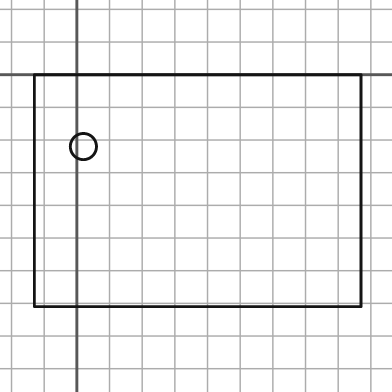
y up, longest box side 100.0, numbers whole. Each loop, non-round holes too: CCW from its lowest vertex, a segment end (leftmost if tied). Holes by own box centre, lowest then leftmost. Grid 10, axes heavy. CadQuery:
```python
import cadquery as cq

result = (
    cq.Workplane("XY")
    .moveTo(-13.0, -71.0)
    .lineTo(87.0, -71.0)
    .lineTo(87.0, 0.0)
    .lineTo(-13.0, 0.0)
    .close()
    .moveTo(2.0, -22.0)
    .circle(4.0)
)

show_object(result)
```